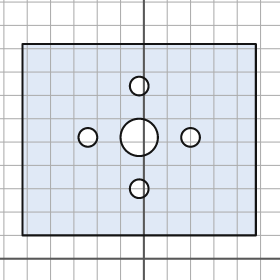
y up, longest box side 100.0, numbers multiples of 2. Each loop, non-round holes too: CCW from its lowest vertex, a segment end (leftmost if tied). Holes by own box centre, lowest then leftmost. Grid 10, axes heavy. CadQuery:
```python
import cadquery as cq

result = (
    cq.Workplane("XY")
    .moveTo(-52.0, 10.0)
    .lineTo(48.0, 10.0)
    .lineTo(48.0, 92.0)
    .lineTo(-52.0, 92.0)
    .close()
    .moveTo(-2.0, 30.0)
    .circle(4.0)
    .moveTo(-24.0, 52.0)
    .circle(4.0)
    .moveTo(-2.0, 52.0)
    .circle(8.0)
    .moveTo(20.0, 52.0)
    .circle(4.0)
    .moveTo(-2.0, 74.0)
    .circle(4.0)
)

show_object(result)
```